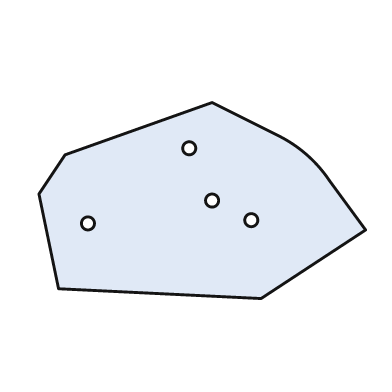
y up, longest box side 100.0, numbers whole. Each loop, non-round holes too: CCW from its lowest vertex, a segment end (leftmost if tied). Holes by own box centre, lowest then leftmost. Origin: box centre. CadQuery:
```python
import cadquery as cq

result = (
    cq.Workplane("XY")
    .moveTo(18.0, -30.0)
    .lineTo(50.0, -9.0)
    .lineTo(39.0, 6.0)
    .threePointArc((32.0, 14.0), (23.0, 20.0))
    .lineTo(3.0, 30.0)
    .lineTo(-42.0, 14.0)
    .lineTo(-50.0, 2.0)
    .lineTo(-44.0, -27.0)
    .close()
    .moveTo(-35.0, -7.0)
    .circle(2.0)
    .moveTo(15.0, -6.0)
    .circle(2.0)
    .moveTo(3.0, 0.0)
    .circle(2.0)
    .moveTo(-4.0, 16.0)
    .circle(2.0)
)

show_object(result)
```